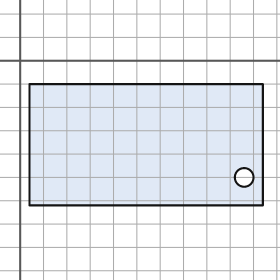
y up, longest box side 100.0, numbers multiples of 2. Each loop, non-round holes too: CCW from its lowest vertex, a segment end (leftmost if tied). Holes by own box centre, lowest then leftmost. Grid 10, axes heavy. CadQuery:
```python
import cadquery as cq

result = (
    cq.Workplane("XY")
    .moveTo(4.0, -62.0)
    .lineTo(104.0, -62.0)
    .lineTo(104.0, -10.0)
    .lineTo(4.0, -10.0)
    .close()
    .moveTo(96.0, -50.0)
    .circle(4.0)
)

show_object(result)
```